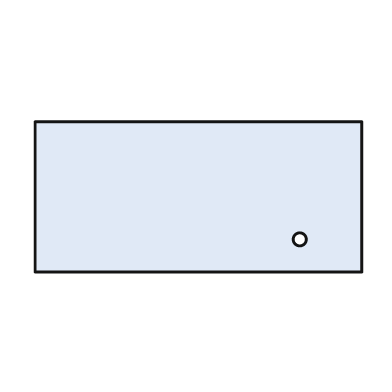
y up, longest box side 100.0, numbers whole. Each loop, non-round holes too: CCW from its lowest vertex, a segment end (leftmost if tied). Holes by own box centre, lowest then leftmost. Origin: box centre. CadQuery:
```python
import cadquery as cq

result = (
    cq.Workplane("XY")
    .moveTo(-50.0, -23.0)
    .lineTo(50.0, -23.0)
    .lineTo(50.0, 23.0)
    .lineTo(-50.0, 23.0)
    .close()
    .moveTo(31.0, -13.0)
    .circle(2.0)
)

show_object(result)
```